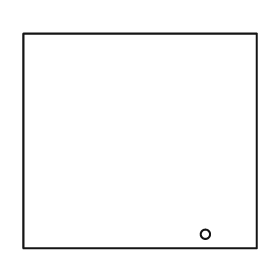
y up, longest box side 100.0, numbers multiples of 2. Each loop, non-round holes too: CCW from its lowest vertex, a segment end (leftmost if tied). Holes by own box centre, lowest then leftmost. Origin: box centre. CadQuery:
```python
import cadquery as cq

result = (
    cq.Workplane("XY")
    .moveTo(-50.0, -46.0)
    .lineTo(50.0, -46.0)
    .lineTo(50.0, 46.0)
    .lineTo(-50.0, 46.0)
    .close()
    .moveTo(28.0, -40.0)
    .circle(2.0)
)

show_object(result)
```